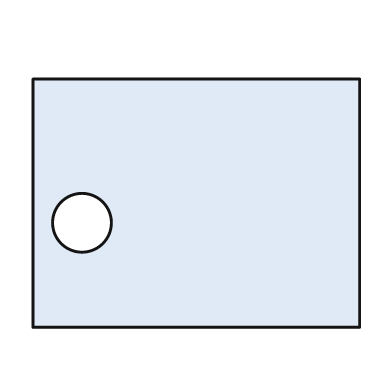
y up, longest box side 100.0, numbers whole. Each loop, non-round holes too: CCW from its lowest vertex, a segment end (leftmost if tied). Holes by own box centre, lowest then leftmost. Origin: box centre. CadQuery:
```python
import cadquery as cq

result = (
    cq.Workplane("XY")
    .moveTo(-50.0, -38.0)
    .lineTo(50.0, -38.0)
    .lineTo(50.0, 38.0)
    .lineTo(-50.0, 38.0)
    .close()
    .moveTo(-35.0, -6.0)
    .circle(9.0)
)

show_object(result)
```